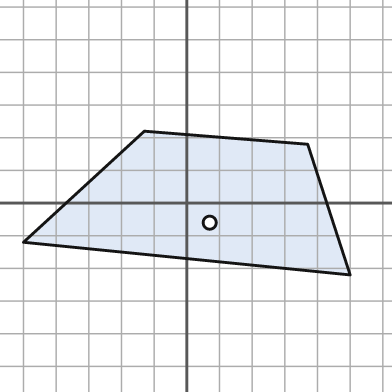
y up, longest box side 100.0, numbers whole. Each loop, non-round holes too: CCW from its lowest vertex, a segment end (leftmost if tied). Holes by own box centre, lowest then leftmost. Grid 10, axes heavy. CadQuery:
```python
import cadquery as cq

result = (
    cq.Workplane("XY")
    .moveTo(50.0, -22.0)
    .lineTo(37.0, 18.0)
    .lineTo(-13.0, 22.0)
    .lineTo(-50.0, -12.0)
    .close()
    .moveTo(7.0, -6.0)
    .circle(2.0)
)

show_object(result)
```